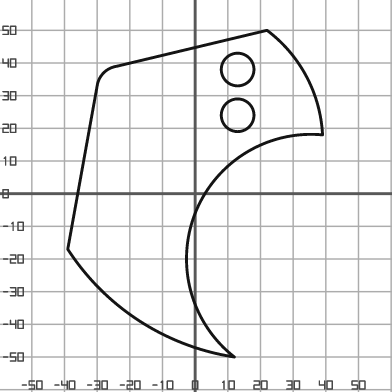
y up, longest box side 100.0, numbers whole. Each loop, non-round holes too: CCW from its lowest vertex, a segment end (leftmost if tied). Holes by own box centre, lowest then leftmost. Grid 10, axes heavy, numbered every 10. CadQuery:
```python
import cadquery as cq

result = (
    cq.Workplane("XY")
    .moveTo(12.0, -50.0)
    .threePointArc((0.0, -6.0), (39.0, 18.0))
    .threePointArc((34.0, 36.0), (22.0, 50.0))
    .lineTo(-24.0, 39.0)
    .threePointArc((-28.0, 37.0), (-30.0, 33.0))
    .lineTo(-39.0, -17.0)
    .threePointArc((-17.0, -39.0), (12.0, -50.0))
    .close()
    .moveTo(13.0, 24.0)
    .circle(5.0)
    .moveTo(13.0, 38.0)
    .circle(5.0)
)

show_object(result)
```